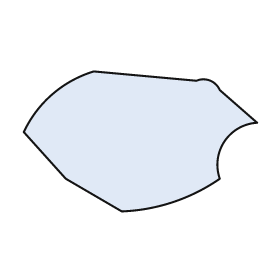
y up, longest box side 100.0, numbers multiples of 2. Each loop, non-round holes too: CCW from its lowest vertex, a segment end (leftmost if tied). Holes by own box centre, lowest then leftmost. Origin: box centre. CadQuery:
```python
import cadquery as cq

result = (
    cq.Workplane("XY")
    .moveTo(-8.0, -30.0)
    .threePointArc((14.0, -26.0), (34.0, -16.0))
    .threePointArc((36.0, 0.0), (50.0, 8.0))
    .lineTo(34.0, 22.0)
    .threePointArc((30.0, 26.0), (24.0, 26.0))
    .lineTo(-20.0, 30.0)
    .threePointArc((-38.0, 20.0), (-50.0, 4.0))
    .lineTo(-32.0, -16.0)
    .close()
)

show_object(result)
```